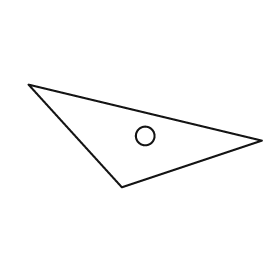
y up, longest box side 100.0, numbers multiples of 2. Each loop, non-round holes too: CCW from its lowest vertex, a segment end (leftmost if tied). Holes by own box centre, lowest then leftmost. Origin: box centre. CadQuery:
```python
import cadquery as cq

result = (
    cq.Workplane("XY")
    .moveTo(-10.0, -22.0)
    .lineTo(50.0, -2.0)
    .lineTo(-50.0, 22.0)
    .close()
    .moveTo(0.0, 0.0)
    .circle(4.0)
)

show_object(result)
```